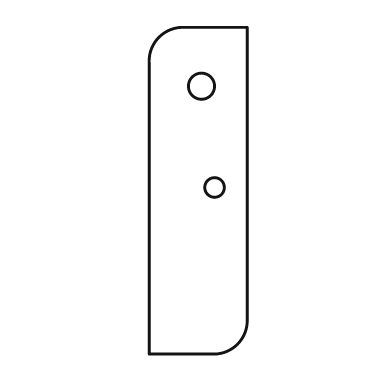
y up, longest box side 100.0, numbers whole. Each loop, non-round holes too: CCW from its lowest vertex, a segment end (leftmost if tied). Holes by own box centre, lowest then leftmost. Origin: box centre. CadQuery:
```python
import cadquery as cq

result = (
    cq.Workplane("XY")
    .moveTo(-15.0, -50.0)
    .lineTo(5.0, -50.0)
    .threePointArc((12.0, -47.0), (15.0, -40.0))
    .lineTo(15.0, 50.0)
    .lineTo(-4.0, 50.0)
    .threePointArc((-12.0, 47.0), (-15.0, 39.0))
    .close()
    .moveTo(5.0, 1.0)
    .circle(3.0)
    .moveTo(1.0, 32.0)
    .circle(4.0)
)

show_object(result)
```